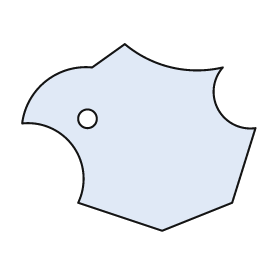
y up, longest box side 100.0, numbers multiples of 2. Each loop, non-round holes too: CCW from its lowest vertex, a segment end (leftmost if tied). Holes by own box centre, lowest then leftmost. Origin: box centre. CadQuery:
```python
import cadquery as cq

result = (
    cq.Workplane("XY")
    .moveTo(10.0, -40.0)
    .lineTo(40.0, -28.0)
    .lineTo(50.0, 4.0)
    .threePointArc((34.0, 12.0), (36.0, 30.0))
    .threePointArc((14.0, 30.0), (-6.0, 40.0))
    .lineTo(-20.0, 30.0)
    .threePointArc((-40.0, 24.0), (-50.0, 6.0))
    .threePointArc((-28.0, -4.0), (-26.0, -28.0))
    .close()
    .moveTo(-22.0, 8.0)
    .circle(4.0)
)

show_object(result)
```